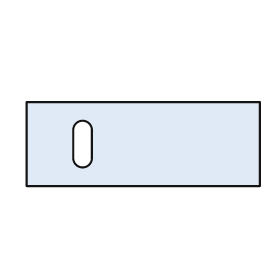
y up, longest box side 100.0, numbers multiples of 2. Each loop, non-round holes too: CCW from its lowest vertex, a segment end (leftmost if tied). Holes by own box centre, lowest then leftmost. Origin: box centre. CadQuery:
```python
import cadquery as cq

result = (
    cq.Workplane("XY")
    .moveTo(-50.0, -18.0)
    .lineTo(50.0, -18.0)
    .lineTo(50.0, 18.0)
    .lineTo(-50.0, 18.0)
    .close()
    .moveTo(-30.0, -6.0)
    .threePointArc((-26.0, -10.0), (-22.0, -6.0))
    .lineTo(-22.0, 6.0)
    .threePointArc((-26.0, 10.0), (-30.0, 6.0))
    .close()
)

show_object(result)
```